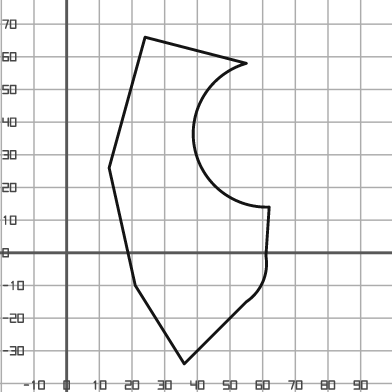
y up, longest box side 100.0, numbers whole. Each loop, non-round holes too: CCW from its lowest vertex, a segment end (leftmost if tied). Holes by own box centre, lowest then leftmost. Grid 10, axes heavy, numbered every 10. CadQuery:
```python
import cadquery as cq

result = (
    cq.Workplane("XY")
    .moveTo(36.0, -34.0)
    .lineTo(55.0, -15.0)
    .threePointArc((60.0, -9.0), (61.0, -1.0))
    .lineTo(62.0, 14.0)
    .threePointArc((39.0, 33.0), (55.0, 58.0))
    .lineTo(24.0, 66.0)
    .lineTo(13.0, 26.0)
    .lineTo(21.0, -10.0)
    .close()
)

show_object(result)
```